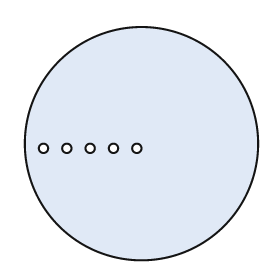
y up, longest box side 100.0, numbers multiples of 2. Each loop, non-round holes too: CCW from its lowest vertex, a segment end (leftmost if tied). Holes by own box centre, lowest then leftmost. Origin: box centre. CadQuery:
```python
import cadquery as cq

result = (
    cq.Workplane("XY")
    .moveTo(0.0, 0.0)
    .circle(50.0)
    .moveTo(-42.0, -2.0)
    .circle(2.0)
    .moveTo(-32.0, -2.0)
    .circle(2.0)
    .moveTo(-22.0, -2.0)
    .circle(2.0)
    .moveTo(-12.0, -2.0)
    .circle(2.0)
    .moveTo(-2.0, -2.0)
    .circle(2.0)
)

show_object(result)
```